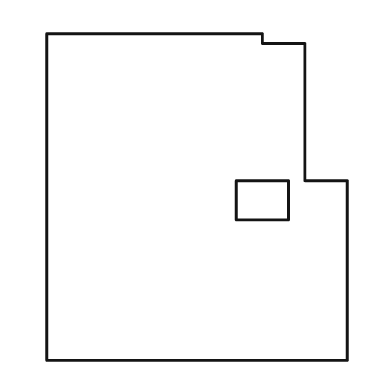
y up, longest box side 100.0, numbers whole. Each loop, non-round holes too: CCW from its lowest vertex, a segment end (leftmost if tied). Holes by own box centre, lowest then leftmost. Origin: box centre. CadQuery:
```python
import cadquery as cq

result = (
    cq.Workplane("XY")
    .moveTo(-46.0, -50.0)
    .lineTo(46.0, -50.0)
    .lineTo(46.0, 5.0)
    .lineTo(33.0, 5.0)
    .lineTo(33.0, 47.0)
    .lineTo(20.0, 47.0)
    .lineTo(20.0, 50.0)
    .lineTo(-46.0, 50.0)
    .close()
    .moveTo(12.0, -7.0)
    .lineTo(28.0, -7.0)
    .lineTo(28.0, 5.0)
    .lineTo(12.0, 5.0)
    .close()
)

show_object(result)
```